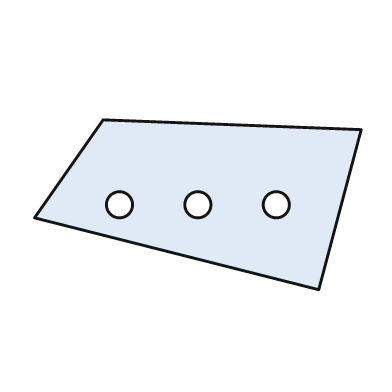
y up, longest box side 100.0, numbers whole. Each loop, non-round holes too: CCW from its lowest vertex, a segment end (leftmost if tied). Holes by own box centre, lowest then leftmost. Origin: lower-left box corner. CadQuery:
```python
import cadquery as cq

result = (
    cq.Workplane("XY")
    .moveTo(87.0, 0.0)
    .lineTo(100.0, 49.0)
    .lineTo(21.0, 52.0)
    .lineTo(0.0, 22.0)
    .close()
    .moveTo(26.0, 26.0)
    .circle(4.0)
    .moveTo(50.0, 26.0)
    .circle(4.0)
    .moveTo(74.0, 26.0)
    .circle(4.0)
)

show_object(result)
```